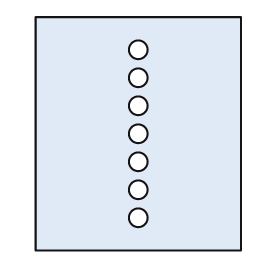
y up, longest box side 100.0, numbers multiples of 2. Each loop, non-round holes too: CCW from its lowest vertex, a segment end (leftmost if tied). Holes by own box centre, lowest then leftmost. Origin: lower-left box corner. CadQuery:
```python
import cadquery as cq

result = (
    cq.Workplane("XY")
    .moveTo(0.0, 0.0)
    .lineTo(88.0, 0.0)
    .lineTo(88.0, 100.0)
    .lineTo(0.0, 100.0)
    .close()
    .moveTo(44.0, 14.0)
    .circle(4.0)
    .moveTo(44.0, 26.0)
    .circle(4.0)
    .moveTo(44.0, 38.0)
    .circle(4.0)
    .moveTo(44.0, 50.0)
    .circle(4.0)
    .moveTo(44.0, 62.0)
    .circle(4.0)
    .moveTo(44.0, 74.0)
    .circle(4.0)
    .moveTo(44.0, 86.0)
    .circle(4.0)
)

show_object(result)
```